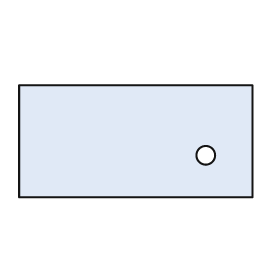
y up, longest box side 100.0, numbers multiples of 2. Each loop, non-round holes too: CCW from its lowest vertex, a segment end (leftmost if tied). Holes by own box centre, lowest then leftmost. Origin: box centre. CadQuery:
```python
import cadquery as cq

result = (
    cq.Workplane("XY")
    .moveTo(-50.0, -24.0)
    .lineTo(50.0, -24.0)
    .lineTo(50.0, 24.0)
    .lineTo(-50.0, 24.0)
    .close()
    .moveTo(30.0, -6.0)
    .circle(4.0)
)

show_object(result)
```